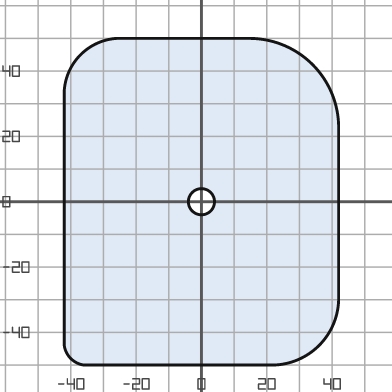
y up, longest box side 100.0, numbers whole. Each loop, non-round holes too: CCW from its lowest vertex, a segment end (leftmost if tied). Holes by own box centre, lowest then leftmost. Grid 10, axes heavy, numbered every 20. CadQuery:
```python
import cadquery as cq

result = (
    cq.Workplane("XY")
    .moveTo(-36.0, -50.0)
    .lineTo(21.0, -50.0)
    .threePointArc((36.0, -44.0), (42.0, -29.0))
    .lineTo(42.0, 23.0)
    .threePointArc((34.0, 42.0), (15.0, 50.0))
    .lineTo(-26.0, 50.0)
    .threePointArc((-37.0, 45.0), (-42.0, 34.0))
    .lineTo(-42.0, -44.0)
    .threePointArc((-40.0, -48.0), (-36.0, -50.0))
    .close()
    .moveTo(0.0, 0.0)
    .circle(4.0)
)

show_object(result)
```